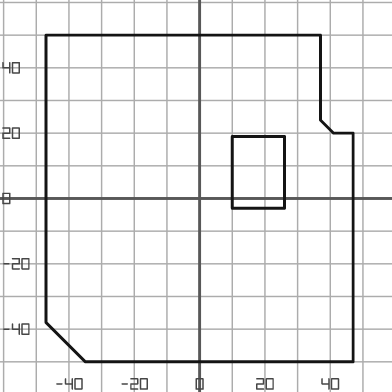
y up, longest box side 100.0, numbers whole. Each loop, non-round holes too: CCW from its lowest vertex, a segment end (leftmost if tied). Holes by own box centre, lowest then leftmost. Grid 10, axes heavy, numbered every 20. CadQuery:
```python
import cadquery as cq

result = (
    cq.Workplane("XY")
    .moveTo(-35.0, -50.0)
    .lineTo(47.0, -50.0)
    .lineTo(47.0, 20.0)
    .lineTo(41.0, 20.0)
    .lineTo(37.0, 24.0)
    .lineTo(37.0, 50.0)
    .lineTo(-47.0, 50.0)
    .lineTo(-47.0, -38.0)
    .close()
    .moveTo(10.0, -3.0)
    .lineTo(26.0, -3.0)
    .lineTo(26.0, 19.0)
    .lineTo(10.0, 19.0)
    .close()
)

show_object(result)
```